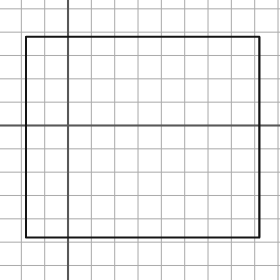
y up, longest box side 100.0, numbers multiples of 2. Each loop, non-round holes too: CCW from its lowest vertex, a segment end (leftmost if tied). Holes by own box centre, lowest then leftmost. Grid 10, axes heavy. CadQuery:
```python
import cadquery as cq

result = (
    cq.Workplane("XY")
    .moveTo(-18.0, -48.0)
    .lineTo(82.0, -48.0)
    .lineTo(82.0, 38.0)
    .lineTo(-18.0, 38.0)
    .close()
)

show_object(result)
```